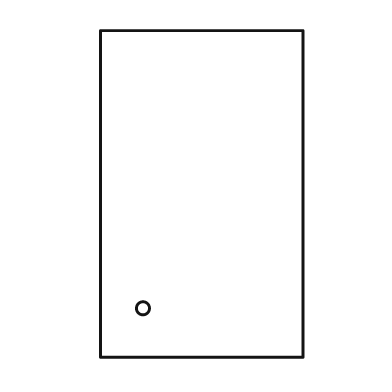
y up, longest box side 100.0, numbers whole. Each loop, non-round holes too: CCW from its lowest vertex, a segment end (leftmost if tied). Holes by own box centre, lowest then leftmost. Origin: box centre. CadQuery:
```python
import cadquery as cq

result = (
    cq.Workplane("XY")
    .moveTo(-31.0, -50.0)
    .lineTo(31.0, -50.0)
    .lineTo(31.0, 50.0)
    .lineTo(-31.0, 50.0)
    .close()
    .moveTo(-18.0, -35.0)
    .circle(2.0)
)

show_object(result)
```